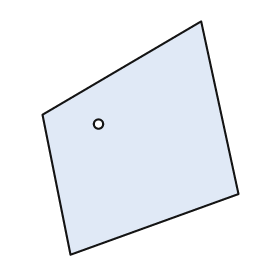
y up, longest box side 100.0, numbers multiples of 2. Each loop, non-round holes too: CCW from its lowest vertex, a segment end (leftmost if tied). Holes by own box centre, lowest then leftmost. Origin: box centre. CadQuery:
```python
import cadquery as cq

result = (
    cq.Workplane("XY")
    .moveTo(-30.0, -50.0)
    .lineTo(42.0, -24.0)
    .lineTo(26.0, 50.0)
    .lineTo(-42.0, 10.0)
    .close()
    .moveTo(-18.0, 6.0)
    .circle(2.0)
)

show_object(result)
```